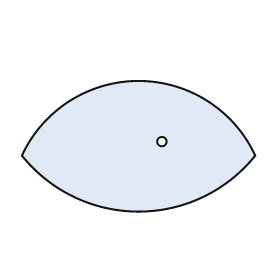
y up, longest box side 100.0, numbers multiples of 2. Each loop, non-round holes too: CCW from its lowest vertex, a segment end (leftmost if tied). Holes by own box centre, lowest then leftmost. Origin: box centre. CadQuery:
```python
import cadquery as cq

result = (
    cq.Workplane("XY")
    .moveTo(-50.0, -4.0)
    .threePointArc((0.0, -28.0), (50.0, -4.0))
    .threePointArc((0.0, 28.0), (-50.0, -4.0))
    .close()
    .moveTo(10.0, 2.0)
    .circle(2.0)
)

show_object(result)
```